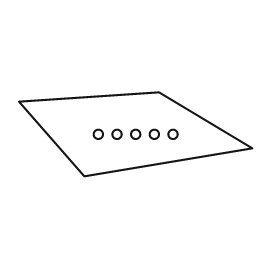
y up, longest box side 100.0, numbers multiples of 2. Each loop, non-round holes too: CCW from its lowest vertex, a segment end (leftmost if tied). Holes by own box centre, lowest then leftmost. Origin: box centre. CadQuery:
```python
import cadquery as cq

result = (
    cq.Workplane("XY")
    .moveTo(-22.0, -18.0)
    .lineTo(50.0, -6.0)
    .lineTo(10.0, 18.0)
    .lineTo(-50.0, 14.0)
    .close()
    .moveTo(-16.0, 0.0)
    .circle(2.0)
    .moveTo(-8.0, 0.0)
    .circle(2.0)
    .moveTo(0.0, 0.0)
    .circle(2.0)
    .moveTo(8.0, 0.0)
    .circle(2.0)
    .moveTo(16.0, 0.0)
    .circle(2.0)
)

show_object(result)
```